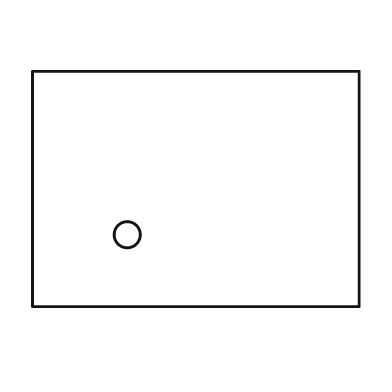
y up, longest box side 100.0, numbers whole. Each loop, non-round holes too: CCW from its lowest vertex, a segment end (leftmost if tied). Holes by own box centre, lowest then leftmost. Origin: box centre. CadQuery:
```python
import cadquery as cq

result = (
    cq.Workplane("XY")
    .moveTo(-50.0, -36.0)
    .lineTo(50.0, -36.0)
    .lineTo(50.0, 36.0)
    .lineTo(-50.0, 36.0)
    .close()
    .moveTo(-21.0, -14.0)
    .circle(4.0)
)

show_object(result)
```